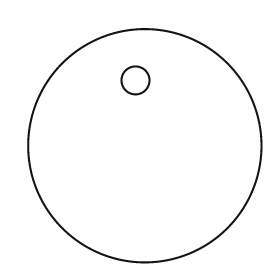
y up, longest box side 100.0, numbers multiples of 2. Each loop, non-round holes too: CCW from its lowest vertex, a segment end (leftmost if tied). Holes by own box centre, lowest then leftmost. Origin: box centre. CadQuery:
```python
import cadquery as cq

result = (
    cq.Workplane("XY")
    .moveTo(0.0, 0.0)
    .circle(50.0)
    .moveTo(-4.0, 28.0)
    .circle(6.0)
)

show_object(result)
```